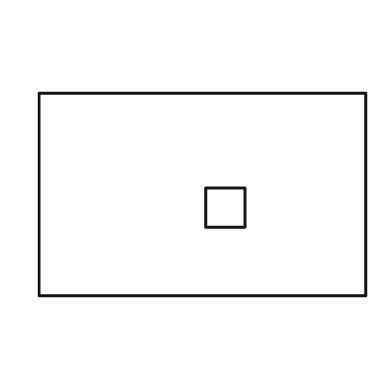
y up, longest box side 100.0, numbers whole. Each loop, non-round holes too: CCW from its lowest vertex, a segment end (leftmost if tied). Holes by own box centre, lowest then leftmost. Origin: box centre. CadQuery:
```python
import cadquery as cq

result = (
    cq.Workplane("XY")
    .moveTo(-50.0, -31.0)
    .lineTo(50.0, -31.0)
    .lineTo(50.0, 31.0)
    .lineTo(-50.0, 31.0)
    .close()
    .moveTo(1.0, -10.0)
    .lineTo(13.0, -10.0)
    .lineTo(13.0, 2.0)
    .lineTo(1.0, 2.0)
    .close()
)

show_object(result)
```